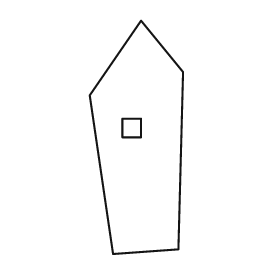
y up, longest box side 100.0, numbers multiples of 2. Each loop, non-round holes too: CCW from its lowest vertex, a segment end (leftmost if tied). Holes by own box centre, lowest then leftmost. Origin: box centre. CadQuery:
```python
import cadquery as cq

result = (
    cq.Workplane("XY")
    .moveTo(-10.0, -50.0)
    .lineTo(18.0, -48.0)
    .lineTo(20.0, 28.0)
    .lineTo(2.0, 50.0)
    .lineTo(-20.0, 18.0)
    .close()
    .moveTo(-6.0, 0.0)
    .lineTo(2.0, 0.0)
    .lineTo(2.0, 8.0)
    .lineTo(-6.0, 8.0)
    .close()
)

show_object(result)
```